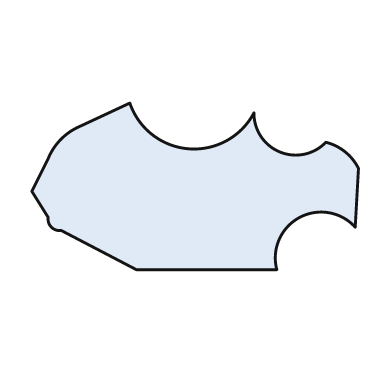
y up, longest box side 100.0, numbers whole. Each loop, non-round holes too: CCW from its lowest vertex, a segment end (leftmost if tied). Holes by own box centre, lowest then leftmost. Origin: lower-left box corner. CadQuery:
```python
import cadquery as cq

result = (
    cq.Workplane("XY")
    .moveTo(32.0, 0.0)
    .lineTo(75.0, 0.0)
    .threePointArc((82.0, 16.0), (99.0, 13.0))
    .lineTo(100.0, 31.0)
    .threePointArc((96.0, 36.0), (90.0, 39.0))
    .threePointArc((76.0, 36.0), (68.0, 48.0))
    .threePointArc((48.0, 37.0), (30.0, 51.0))
    .lineTo(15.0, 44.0)
    .threePointArc((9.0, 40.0), (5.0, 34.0))
    .lineTo(0.0, 24.0)
    .lineTo(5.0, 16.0)
    .threePointArc((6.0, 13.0), (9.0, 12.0))
    .close()
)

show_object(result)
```